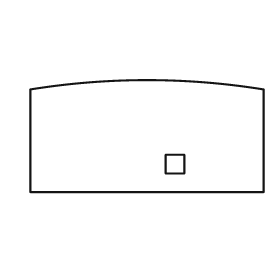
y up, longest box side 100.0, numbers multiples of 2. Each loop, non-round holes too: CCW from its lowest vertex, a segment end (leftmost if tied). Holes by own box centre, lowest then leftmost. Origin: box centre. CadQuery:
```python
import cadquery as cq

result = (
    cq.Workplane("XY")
    .moveTo(-50.0, -24.0)
    .lineTo(50.0, -24.0)
    .lineTo(50.0, 20.0)
    .threePointArc((0.0, 24.0), (-50.0, 20.0))
    .close()
    .moveTo(8.0, -16.0)
    .lineTo(16.0, -16.0)
    .lineTo(16.0, -8.0)
    .lineTo(8.0, -8.0)
    .close()
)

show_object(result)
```